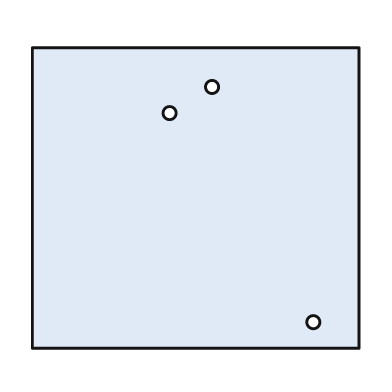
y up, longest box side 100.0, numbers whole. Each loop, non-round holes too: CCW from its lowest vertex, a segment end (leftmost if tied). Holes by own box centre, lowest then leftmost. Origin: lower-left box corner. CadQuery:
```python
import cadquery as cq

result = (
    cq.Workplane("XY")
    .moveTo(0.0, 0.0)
    .lineTo(100.0, 0.0)
    .lineTo(100.0, 92.0)
    .lineTo(0.0, 92.0)
    .close()
    .moveTo(86.0, 8.0)
    .circle(2.0)
    .moveTo(42.0, 72.0)
    .circle(2.0)
    .moveTo(55.0, 80.0)
    .circle(2.0)
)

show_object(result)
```